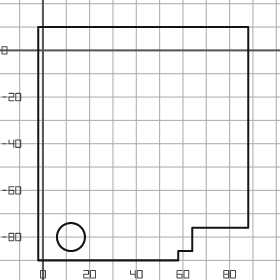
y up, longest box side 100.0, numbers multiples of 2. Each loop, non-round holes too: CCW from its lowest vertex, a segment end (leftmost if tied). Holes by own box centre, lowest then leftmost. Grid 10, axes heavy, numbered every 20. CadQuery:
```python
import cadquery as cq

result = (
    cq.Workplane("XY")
    .moveTo(-2.0, -90.0)
    .lineTo(58.0, -90.0)
    .lineTo(58.0, -86.0)
    .lineTo(64.0, -86.0)
    .lineTo(64.0, -76.0)
    .lineTo(88.0, -76.0)
    .lineTo(88.0, 10.0)
    .lineTo(-2.0, 10.0)
    .close()
    .moveTo(12.0, -80.0)
    .circle(6.0)
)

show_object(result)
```